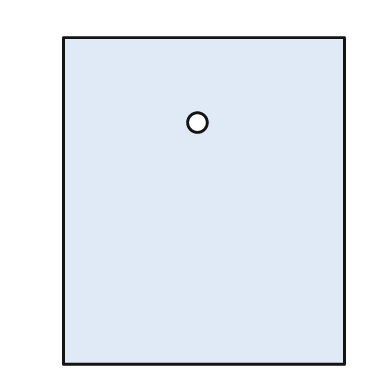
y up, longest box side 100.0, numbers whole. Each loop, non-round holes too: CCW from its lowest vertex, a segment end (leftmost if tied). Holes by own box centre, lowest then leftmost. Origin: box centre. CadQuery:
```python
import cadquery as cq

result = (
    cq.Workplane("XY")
    .moveTo(-43.0, -50.0)
    .lineTo(43.0, -50.0)
    .lineTo(43.0, 50.0)
    .lineTo(-43.0, 50.0)
    .close()
    .moveTo(-2.0, 24.0)
    .circle(3.0)
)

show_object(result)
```